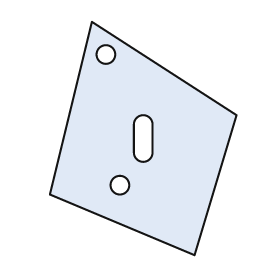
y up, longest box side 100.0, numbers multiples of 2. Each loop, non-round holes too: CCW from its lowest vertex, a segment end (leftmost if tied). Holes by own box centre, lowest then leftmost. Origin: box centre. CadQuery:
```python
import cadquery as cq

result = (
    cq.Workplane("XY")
    .moveTo(22.0, -50.0)
    .lineTo(40.0, 10.0)
    .lineTo(-22.0, 50.0)
    .lineTo(-40.0, -24.0)
    .close()
    .moveTo(-10.0, -20.0)
    .circle(4.0)
    .moveTo(-4.0, -6.0)
    .threePointArc((0.0, -10.0), (4.0, -6.0))
    .lineTo(4.0, 6.0)
    .threePointArc((0.0, 10.0), (-4.0, 6.0))
    .close()
    .moveTo(-16.0, 36.0)
    .circle(4.0)
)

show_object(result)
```